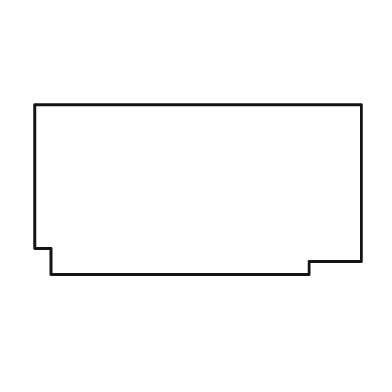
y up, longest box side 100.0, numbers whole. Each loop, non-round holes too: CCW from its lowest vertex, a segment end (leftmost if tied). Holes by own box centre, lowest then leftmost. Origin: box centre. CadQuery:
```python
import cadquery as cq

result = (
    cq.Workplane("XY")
    .moveTo(-45.0, -26.0)
    .lineTo(34.0, -26.0)
    .lineTo(34.0, -22.0)
    .lineTo(50.0, -22.0)
    .lineTo(50.0, 26.0)
    .lineTo(-50.0, 26.0)
    .lineTo(-50.0, -18.0)
    .lineTo(-45.0, -18.0)
    .close()
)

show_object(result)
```